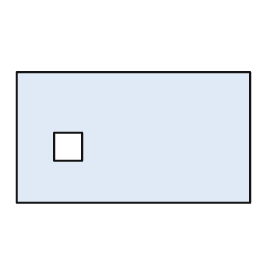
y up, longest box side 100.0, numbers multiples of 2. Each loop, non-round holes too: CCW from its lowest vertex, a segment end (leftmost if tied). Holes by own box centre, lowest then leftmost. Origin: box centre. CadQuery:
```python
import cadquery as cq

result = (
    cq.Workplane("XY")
    .moveTo(-50.0, -28.0)
    .lineTo(50.0, -28.0)
    .lineTo(50.0, 28.0)
    .lineTo(-50.0, 28.0)
    .close()
    .moveTo(-34.0, -10.0)
    .lineTo(-22.0, -10.0)
    .lineTo(-22.0, 2.0)
    .lineTo(-34.0, 2.0)
    .close()
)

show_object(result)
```